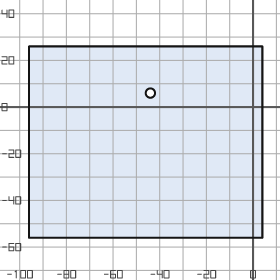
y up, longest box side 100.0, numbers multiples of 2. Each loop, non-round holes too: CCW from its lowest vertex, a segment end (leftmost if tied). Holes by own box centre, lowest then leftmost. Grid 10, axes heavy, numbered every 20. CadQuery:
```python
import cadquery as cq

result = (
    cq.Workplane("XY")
    .moveTo(-96.0, -56.0)
    .lineTo(4.0, -56.0)
    .lineTo(4.0, 26.0)
    .lineTo(-96.0, 26.0)
    .close()
    .moveTo(-44.0, 6.0)
    .circle(2.0)
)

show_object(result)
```